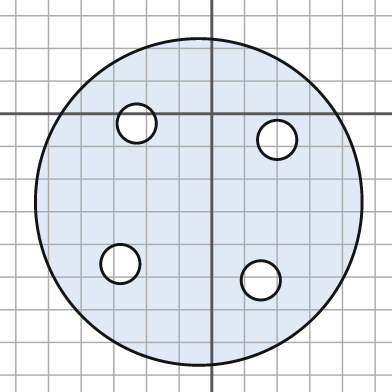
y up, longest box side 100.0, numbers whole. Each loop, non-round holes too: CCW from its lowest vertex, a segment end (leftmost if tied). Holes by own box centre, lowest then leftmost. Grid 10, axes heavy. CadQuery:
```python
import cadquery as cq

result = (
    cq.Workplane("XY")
    .moveTo(-4.0, -27.0)
    .circle(50.0)
    .moveTo(15.0, -51.0)
    .circle(6.0)
    .moveTo(-28.0, -46.0)
    .circle(6.0)
    .moveTo(20.0, -8.0)
    .circle(6.0)
    .moveTo(-23.0, -3.0)
    .circle(6.0)
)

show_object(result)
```